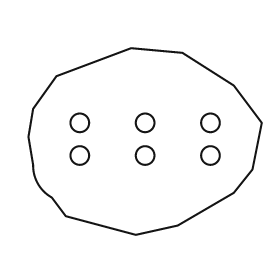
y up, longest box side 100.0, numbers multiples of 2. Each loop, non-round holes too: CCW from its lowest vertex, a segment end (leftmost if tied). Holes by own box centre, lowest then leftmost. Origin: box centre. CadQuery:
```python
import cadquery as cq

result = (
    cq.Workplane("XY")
    .moveTo(-4.0, -40.0)
    .lineTo(14.0, -36.0)
    .lineTo(38.0, -22.0)
    .lineTo(46.0, -12.0)
    .lineTo(50.0, 8.0)
    .lineTo(38.0, 24.0)
    .lineTo(16.0, 38.0)
    .lineTo(-6.0, 40.0)
    .lineTo(-38.0, 28.0)
    .lineTo(-48.0, 14.0)
    .lineTo(-50.0, 2.0)
    .lineTo(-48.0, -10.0)
    .threePointArc((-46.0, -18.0), (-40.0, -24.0))
    .lineTo(-34.0, -32.0)
    .close()
    .moveTo(-28.0, -6.0)
    .circle(4.0)
    .moveTo(0.0, -6.0)
    .circle(4.0)
    .moveTo(28.0, -6.0)
    .circle(4.0)
    .moveTo(-28.0, 8.0)
    .circle(4.0)
    .moveTo(0.0, 8.0)
    .circle(4.0)
    .moveTo(28.0, 8.0)
    .circle(4.0)
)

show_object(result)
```